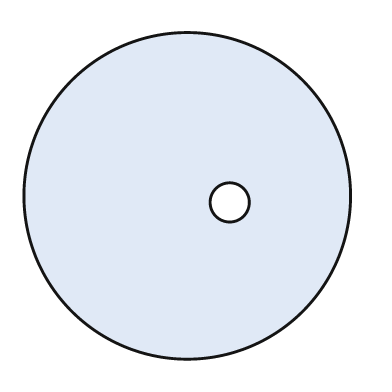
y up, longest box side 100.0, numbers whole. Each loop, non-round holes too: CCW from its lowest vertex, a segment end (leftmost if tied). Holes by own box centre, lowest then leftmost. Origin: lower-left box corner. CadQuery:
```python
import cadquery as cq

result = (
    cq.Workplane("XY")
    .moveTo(50.0, 50.0)
    .circle(50.0)
    .moveTo(63.0, 48.0)
    .circle(6.0)
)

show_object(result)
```